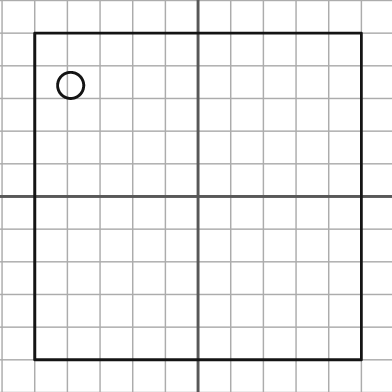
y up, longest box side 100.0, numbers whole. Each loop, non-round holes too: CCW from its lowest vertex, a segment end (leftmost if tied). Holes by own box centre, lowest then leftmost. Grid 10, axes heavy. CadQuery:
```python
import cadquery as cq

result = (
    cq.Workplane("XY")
    .moveTo(-50.0, -50.0)
    .lineTo(50.0, -50.0)
    .lineTo(50.0, 50.0)
    .lineTo(-50.0, 50.0)
    .close()
    .moveTo(-39.0, 34.0)
    .circle(4.0)
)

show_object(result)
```